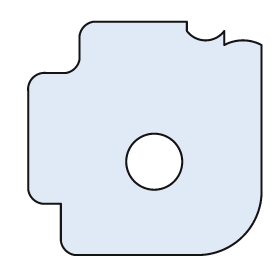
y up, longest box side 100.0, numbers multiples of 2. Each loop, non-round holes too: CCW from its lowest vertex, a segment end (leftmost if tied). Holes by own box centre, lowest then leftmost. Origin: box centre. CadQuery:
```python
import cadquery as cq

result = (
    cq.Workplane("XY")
    .moveTo(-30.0, -50.0)
    .lineTo(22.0, -50.0)
    .threePointArc((42.0, -42.0), (50.0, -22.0))
    .lineTo(50.0, 40.0)
    .threePointArc((42.0, 42.0), (34.0, 40.0))
    .lineTo(34.0, 46.0)
    .threePointArc((26.0, 42.0), (18.0, 46.0))
    .lineTo(18.0, 50.0)
    .lineTo(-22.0, 50.0)
    .threePointArc((-26.0, 48.0), (-28.0, 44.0))
    .lineTo(-28.0, 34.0)
    .threePointArc((-30.0, 30.0), (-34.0, 28.0))
    .lineTo(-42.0, 28.0)
    .threePointArc((-48.0, 26.0), (-50.0, 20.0))
    .lineTo(-50.0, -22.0)
    .threePointArc((-48.0, -26.0), (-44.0, -28.0))
    .lineTo(-36.0, -28.0)
    .lineTo(-36.0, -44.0)
    .threePointArc((-34.0, -48.0), (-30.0, -50.0))
    .close()
    .moveTo(4.0, -10.0)
    .circle(12.0)
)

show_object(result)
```